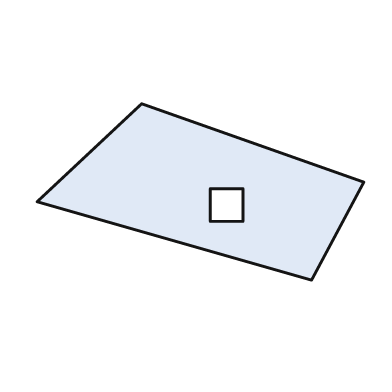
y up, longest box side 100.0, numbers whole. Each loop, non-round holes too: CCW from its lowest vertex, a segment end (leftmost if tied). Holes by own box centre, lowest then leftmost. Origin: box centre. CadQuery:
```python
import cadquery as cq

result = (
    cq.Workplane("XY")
    .moveTo(34.0, -27.0)
    .lineTo(50.0, 3.0)
    .lineTo(-18.0, 27.0)
    .lineTo(-50.0, -3.0)
    .close()
    .moveTo(3.0, -9.0)
    .lineTo(13.0, -9.0)
    .lineTo(13.0, 1.0)
    .lineTo(3.0, 1.0)
    .close()
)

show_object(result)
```